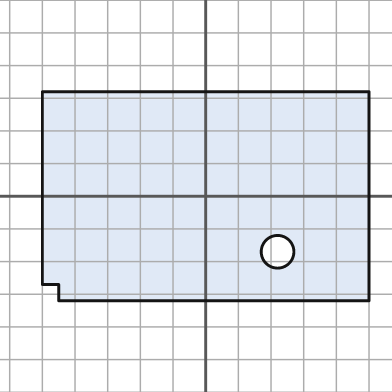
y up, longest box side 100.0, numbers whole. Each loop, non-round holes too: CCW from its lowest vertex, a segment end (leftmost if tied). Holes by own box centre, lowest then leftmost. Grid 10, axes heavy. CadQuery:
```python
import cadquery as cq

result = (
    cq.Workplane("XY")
    .moveTo(-45.0, -32.0)
    .lineTo(50.0, -32.0)
    .lineTo(50.0, 32.0)
    .lineTo(-50.0, 32.0)
    .lineTo(-50.0, -27.0)
    .lineTo(-45.0, -27.0)
    .close()
    .moveTo(22.0, -17.0)
    .circle(5.0)
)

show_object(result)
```